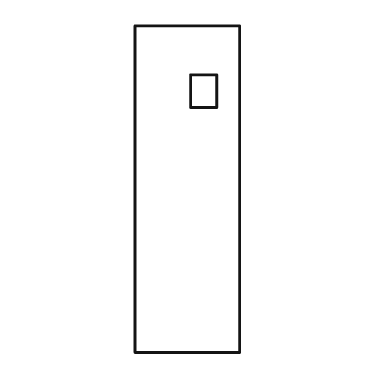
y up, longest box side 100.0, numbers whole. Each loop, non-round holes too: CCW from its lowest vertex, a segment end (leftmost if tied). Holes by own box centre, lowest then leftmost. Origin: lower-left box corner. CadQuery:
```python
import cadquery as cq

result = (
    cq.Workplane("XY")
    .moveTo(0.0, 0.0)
    .lineTo(32.0, 0.0)
    .lineTo(32.0, 100.0)
    .lineTo(0.0, 100.0)
    .close()
    .moveTo(17.0, 75.0)
    .lineTo(25.0, 75.0)
    .lineTo(25.0, 85.0)
    .lineTo(17.0, 85.0)
    .close()
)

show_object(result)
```